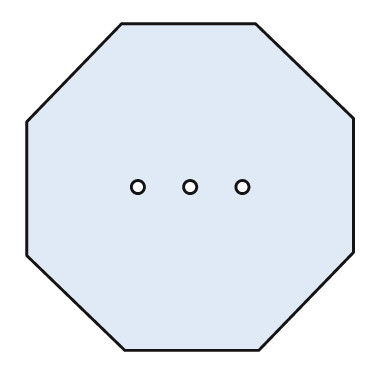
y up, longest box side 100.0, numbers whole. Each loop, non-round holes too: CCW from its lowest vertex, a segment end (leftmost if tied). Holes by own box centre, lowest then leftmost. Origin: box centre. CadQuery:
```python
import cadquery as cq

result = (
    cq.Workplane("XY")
    .moveTo(-20.0, -50.0)
    .lineTo(21.0, -50.0)
    .lineTo(50.0, -20.0)
    .lineTo(50.0, 21.0)
    .lineTo(20.0, 50.0)
    .lineTo(-21.0, 50.0)
    .lineTo(-50.0, 20.0)
    .lineTo(-50.0, -21.0)
    .close()
    .moveTo(-16.0, 0.0)
    .circle(2.0)
    .moveTo(0.0, 0.0)
    .circle(2.0)
    .moveTo(16.0, 0.0)
    .circle(2.0)
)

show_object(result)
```